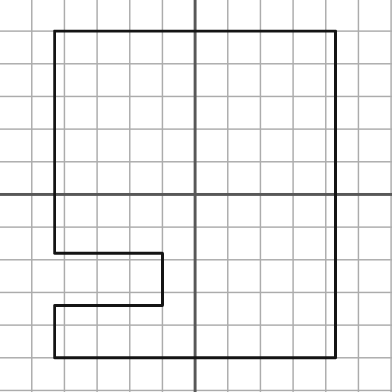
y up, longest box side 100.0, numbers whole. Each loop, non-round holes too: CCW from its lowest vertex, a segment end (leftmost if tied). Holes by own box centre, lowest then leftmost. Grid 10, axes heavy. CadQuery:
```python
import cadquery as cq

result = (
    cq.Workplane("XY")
    .moveTo(-43.0, -50.0)
    .lineTo(43.0, -50.0)
    .lineTo(43.0, 50.0)
    .lineTo(-43.0, 50.0)
    .lineTo(-43.0, -18.0)
    .lineTo(-10.0, -18.0)
    .lineTo(-10.0, -34.0)
    .lineTo(-43.0, -34.0)
    .close()
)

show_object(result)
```